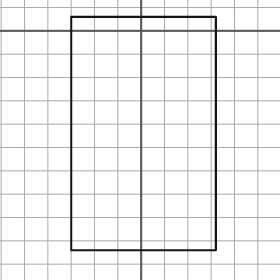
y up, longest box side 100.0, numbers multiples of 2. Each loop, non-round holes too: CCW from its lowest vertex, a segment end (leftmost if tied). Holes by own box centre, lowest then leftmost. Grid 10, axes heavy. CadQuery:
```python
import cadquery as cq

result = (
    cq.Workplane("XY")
    .moveTo(-30.0, -94.0)
    .lineTo(32.0, -94.0)
    .lineTo(32.0, 6.0)
    .lineTo(-30.0, 6.0)
    .close()
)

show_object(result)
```